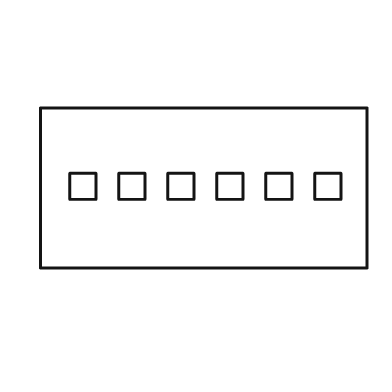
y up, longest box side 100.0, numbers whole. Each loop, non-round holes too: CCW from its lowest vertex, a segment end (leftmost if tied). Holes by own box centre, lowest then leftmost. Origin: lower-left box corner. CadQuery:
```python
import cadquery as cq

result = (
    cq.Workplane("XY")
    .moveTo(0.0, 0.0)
    .lineTo(100.0, 0.0)
    .lineTo(100.0, 49.0)
    .lineTo(0.0, 49.0)
    .close()
    .moveTo(9.0, 21.0)
    .lineTo(17.0, 21.0)
    .lineTo(17.0, 29.0)
    .lineTo(9.0, 29.0)
    .close()
    .moveTo(24.0, 21.0)
    .lineTo(32.0, 21.0)
    .lineTo(32.0, 29.0)
    .lineTo(24.0, 29.0)
    .close()
    .moveTo(39.0, 21.0)
    .lineTo(47.0, 21.0)
    .lineTo(47.0, 29.0)
    .lineTo(39.0, 29.0)
    .close()
    .moveTo(54.0, 21.0)
    .lineTo(62.0, 21.0)
    .lineTo(62.0, 29.0)
    .lineTo(54.0, 29.0)
    .close()
    .moveTo(69.0, 21.0)
    .lineTo(77.0, 21.0)
    .lineTo(77.0, 29.0)
    .lineTo(69.0, 29.0)
    .close()
    .moveTo(84.0, 21.0)
    .lineTo(92.0, 21.0)
    .lineTo(92.0, 29.0)
    .lineTo(84.0, 29.0)
    .close()
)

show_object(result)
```